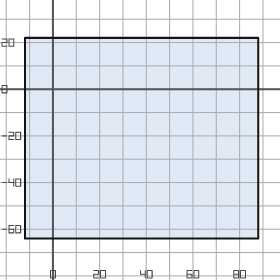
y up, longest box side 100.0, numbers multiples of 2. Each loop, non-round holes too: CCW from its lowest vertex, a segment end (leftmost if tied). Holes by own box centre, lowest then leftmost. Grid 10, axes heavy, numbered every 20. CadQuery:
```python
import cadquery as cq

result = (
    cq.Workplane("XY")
    .moveTo(-12.0, -64.0)
    .lineTo(88.0, -64.0)
    .lineTo(88.0, 22.0)
    .lineTo(-12.0, 22.0)
    .close()
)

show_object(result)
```